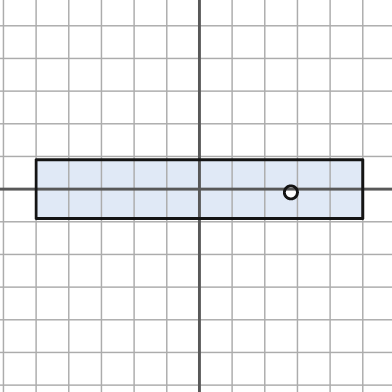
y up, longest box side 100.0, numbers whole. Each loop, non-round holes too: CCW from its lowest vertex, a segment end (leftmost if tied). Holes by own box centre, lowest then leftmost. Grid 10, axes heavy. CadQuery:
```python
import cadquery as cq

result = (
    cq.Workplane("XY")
    .moveTo(-50.0, -9.0)
    .lineTo(50.0, -9.0)
    .lineTo(50.0, 9.0)
    .lineTo(-50.0, 9.0)
    .close()
    .moveTo(28.0, -1.0)
    .circle(2.0)
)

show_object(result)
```